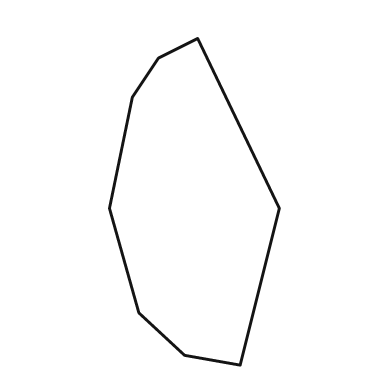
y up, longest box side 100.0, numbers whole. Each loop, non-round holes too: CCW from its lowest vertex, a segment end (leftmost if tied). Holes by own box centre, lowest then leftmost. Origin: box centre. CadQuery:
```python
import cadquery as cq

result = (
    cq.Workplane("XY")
    .moveTo(14.0, -50.0)
    .lineTo(26.0, -2.0)
    .lineTo(1.0, 50.0)
    .lineTo(-11.0, 44.0)
    .lineTo(-19.0, 32.0)
    .lineTo(-26.0, -2.0)
    .lineTo(-17.0, -34.0)
    .lineTo(-3.0, -47.0)
    .close()
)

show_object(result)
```